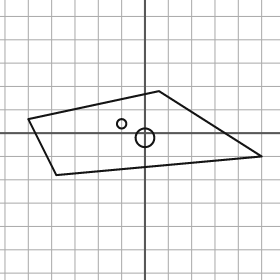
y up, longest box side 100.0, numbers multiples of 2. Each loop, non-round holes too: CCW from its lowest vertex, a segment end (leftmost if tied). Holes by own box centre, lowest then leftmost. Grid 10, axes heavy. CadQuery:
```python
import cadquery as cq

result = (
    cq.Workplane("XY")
    .moveTo(-38.0, -18.0)
    .lineTo(50.0, -10.0)
    .lineTo(6.0, 18.0)
    .lineTo(-50.0, 6.0)
    .close()
    .moveTo(0.0, -2.0)
    .circle(4.0)
    .moveTo(-10.0, 4.0)
    .circle(2.0)
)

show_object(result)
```